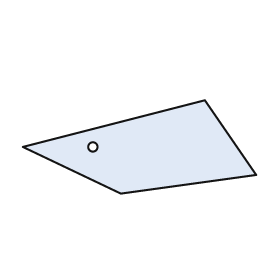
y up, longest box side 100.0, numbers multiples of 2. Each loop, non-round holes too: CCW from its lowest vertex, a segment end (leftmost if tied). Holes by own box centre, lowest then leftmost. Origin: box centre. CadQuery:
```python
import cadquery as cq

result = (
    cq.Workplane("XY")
    .moveTo(-8.0, -20.0)
    .lineTo(50.0, -12.0)
    .lineTo(28.0, 20.0)
    .lineTo(-50.0, 0.0)
    .close()
    .moveTo(-20.0, 0.0)
    .circle(2.0)
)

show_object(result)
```